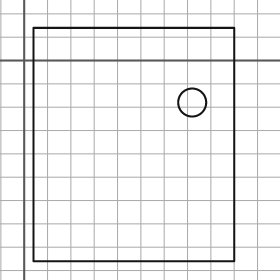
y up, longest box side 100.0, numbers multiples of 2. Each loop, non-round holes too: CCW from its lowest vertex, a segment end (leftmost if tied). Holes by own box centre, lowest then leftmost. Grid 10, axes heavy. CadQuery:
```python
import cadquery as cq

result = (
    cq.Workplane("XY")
    .moveTo(4.0, -86.0)
    .lineTo(90.0, -86.0)
    .lineTo(90.0, 14.0)
    .lineTo(4.0, 14.0)
    .close()
    .moveTo(72.0, -18.0)
    .circle(6.0)
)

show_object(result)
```